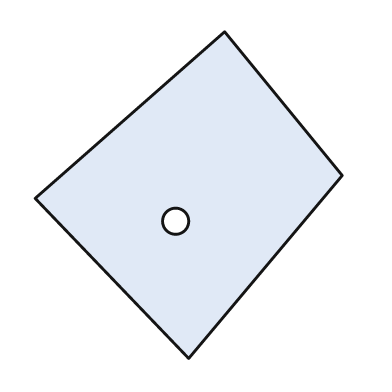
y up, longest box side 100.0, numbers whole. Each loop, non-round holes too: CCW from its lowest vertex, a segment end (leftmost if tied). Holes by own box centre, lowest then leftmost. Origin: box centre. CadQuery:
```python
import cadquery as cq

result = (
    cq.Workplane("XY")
    .moveTo(0.0, -50.0)
    .lineTo(47.0, 6.0)
    .lineTo(11.0, 50.0)
    .lineTo(-47.0, -1.0)
    .close()
    .moveTo(-4.0, -8.0)
    .circle(4.0)
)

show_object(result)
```